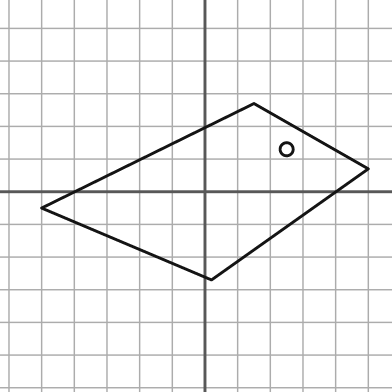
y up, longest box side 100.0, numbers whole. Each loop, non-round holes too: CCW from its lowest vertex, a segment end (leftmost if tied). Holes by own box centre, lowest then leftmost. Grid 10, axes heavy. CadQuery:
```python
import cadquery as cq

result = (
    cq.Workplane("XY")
    .moveTo(2.0, -27.0)
    .lineTo(50.0, 7.0)
    .lineTo(15.0, 27.0)
    .lineTo(-50.0, -5.0)
    .close()
    .moveTo(25.0, 13.0)
    .circle(2.0)
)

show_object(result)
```